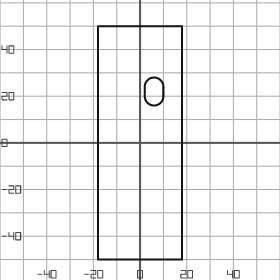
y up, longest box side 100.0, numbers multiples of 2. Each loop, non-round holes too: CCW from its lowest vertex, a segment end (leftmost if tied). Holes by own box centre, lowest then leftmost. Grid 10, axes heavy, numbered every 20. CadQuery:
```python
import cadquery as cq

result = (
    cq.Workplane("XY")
    .moveTo(-18.0, -50.0)
    .lineTo(18.0, -50.0)
    .lineTo(18.0, 50.0)
    .lineTo(-18.0, 50.0)
    .close()
    .moveTo(2.0, 20.0)
    .threePointArc((6.0, 16.0), (10.0, 20.0))
    .lineTo(10.0, 24.0)
    .threePointArc((6.0, 28.0), (2.0, 24.0))
    .close()
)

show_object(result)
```